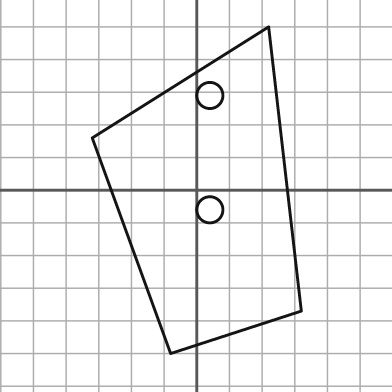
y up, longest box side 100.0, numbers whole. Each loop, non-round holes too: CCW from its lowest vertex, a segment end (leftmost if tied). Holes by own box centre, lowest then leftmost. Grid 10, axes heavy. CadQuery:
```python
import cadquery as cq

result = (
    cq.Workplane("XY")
    .moveTo(-8.0, -50.0)
    .lineTo(32.0, -37.0)
    .lineTo(22.0, 50.0)
    .lineTo(-32.0, 16.0)
    .close()
    .moveTo(4.0, -6.0)
    .circle(4.0)
    .moveTo(4.0, 29.0)
    .circle(4.0)
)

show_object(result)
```